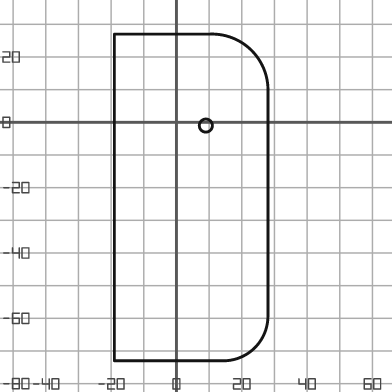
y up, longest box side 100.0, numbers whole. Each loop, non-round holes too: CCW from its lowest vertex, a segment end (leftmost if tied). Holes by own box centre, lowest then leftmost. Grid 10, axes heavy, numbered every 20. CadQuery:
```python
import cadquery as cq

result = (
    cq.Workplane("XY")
    .moveTo(-19.0, -73.0)
    .lineTo(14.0, -73.0)
    .threePointArc((24.0, -69.0), (28.0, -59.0))
    .lineTo(28.0, 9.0)
    .threePointArc((23.0, 22.0), (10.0, 27.0))
    .lineTo(-19.0, 27.0)
    .close()
    .moveTo(9.0, -1.0)
    .circle(2.0)
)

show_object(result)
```